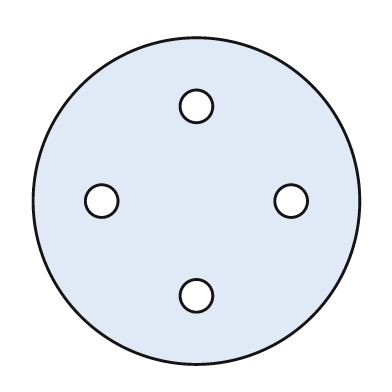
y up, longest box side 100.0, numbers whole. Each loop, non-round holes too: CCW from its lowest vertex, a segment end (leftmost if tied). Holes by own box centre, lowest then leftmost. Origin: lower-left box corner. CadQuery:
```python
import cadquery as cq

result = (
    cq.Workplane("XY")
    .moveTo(50.0, 50.0)
    .circle(50.0)
    .moveTo(50.0, 21.0)
    .circle(5.0)
    .moveTo(21.0, 50.0)
    .circle(5.0)
    .moveTo(79.0, 50.0)
    .circle(5.0)
    .moveTo(50.0, 79.0)
    .circle(5.0)
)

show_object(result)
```